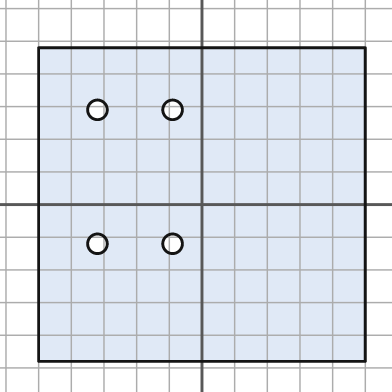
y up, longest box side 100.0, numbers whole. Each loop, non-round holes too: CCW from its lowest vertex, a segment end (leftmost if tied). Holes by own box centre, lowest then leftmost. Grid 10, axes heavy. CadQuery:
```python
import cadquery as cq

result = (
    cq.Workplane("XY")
    .moveTo(-50.0, -48.0)
    .lineTo(50.0, -48.0)
    .lineTo(50.0, 48.0)
    .lineTo(-50.0, 48.0)
    .close()
    .moveTo(-32.0, -12.0)
    .circle(3.0)
    .moveTo(-9.0, -12.0)
    .circle(3.0)
    .moveTo(-32.0, 29.0)
    .circle(3.0)
    .moveTo(-9.0, 29.0)
    .circle(3.0)
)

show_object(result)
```